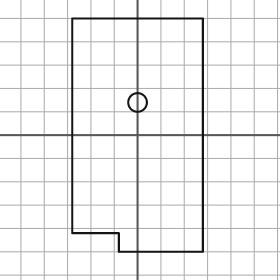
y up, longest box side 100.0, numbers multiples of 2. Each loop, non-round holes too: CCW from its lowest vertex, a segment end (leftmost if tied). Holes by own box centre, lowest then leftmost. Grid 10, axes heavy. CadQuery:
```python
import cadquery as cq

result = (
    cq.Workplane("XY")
    .moveTo(-8.0, -50.0)
    .lineTo(28.0, -50.0)
    .lineTo(28.0, 50.0)
    .lineTo(-28.0, 50.0)
    .lineTo(-28.0, -42.0)
    .lineTo(-8.0, -42.0)
    .close()
    .moveTo(0.0, 14.0)
    .circle(4.0)
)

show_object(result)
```